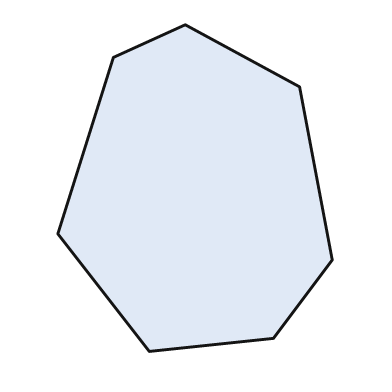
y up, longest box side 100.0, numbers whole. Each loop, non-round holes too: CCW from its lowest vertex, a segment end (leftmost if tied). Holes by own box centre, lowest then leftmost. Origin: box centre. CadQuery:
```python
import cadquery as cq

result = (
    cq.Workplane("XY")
    .moveTo(-14.0, -50.0)
    .lineTo(24.0, -46.0)
    .lineTo(42.0, -22.0)
    .lineTo(32.0, 31.0)
    .lineTo(-3.0, 50.0)
    .lineTo(-25.0, 40.0)
    .lineTo(-42.0, -14.0)
    .close()
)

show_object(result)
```